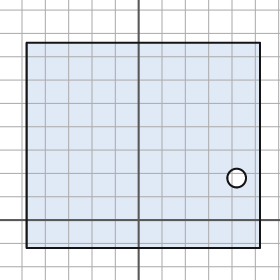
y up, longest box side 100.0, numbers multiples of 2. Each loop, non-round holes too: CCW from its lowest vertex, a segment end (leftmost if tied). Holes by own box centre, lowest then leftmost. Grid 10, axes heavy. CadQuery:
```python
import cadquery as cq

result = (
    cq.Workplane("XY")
    .moveTo(-48.0, -12.0)
    .lineTo(52.0, -12.0)
    .lineTo(52.0, 76.0)
    .lineTo(-48.0, 76.0)
    .close()
    .moveTo(42.0, 18.0)
    .circle(4.0)
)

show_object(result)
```